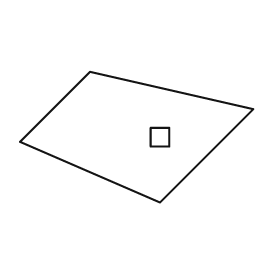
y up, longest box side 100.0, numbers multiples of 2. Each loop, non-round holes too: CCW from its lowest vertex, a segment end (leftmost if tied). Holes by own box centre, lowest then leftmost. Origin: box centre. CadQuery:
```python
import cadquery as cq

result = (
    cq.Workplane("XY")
    .moveTo(10.0, -28.0)
    .lineTo(50.0, 12.0)
    .lineTo(-20.0, 28.0)
    .lineTo(-50.0, -2.0)
    .close()
    .moveTo(6.0, -4.0)
    .lineTo(14.0, -4.0)
    .lineTo(14.0, 4.0)
    .lineTo(6.0, 4.0)
    .close()
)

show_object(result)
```